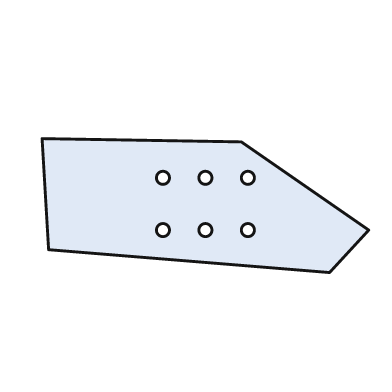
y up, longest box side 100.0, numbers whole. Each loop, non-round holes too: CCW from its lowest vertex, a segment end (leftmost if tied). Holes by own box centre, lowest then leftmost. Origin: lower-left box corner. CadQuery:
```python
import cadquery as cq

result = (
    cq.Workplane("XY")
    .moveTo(88.0, 0.0)
    .lineTo(100.0, 13.0)
    .lineTo(61.0, 40.0)
    .lineTo(0.0, 41.0)
    .lineTo(2.0, 7.0)
    .close()
    .moveTo(37.0, 13.0)
    .circle(2.0)
    .moveTo(50.0, 13.0)
    .circle(2.0)
    .moveTo(63.0, 13.0)
    .circle(2.0)
    .moveTo(37.0, 29.0)
    .circle(2.0)
    .moveTo(50.0, 29.0)
    .circle(2.0)
    .moveTo(63.0, 29.0)
    .circle(2.0)
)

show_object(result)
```